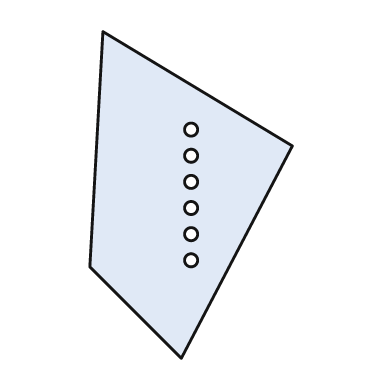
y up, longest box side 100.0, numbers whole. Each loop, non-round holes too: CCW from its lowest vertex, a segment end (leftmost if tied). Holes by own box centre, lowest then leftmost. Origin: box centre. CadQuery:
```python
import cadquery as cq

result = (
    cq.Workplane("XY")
    .moveTo(-3.0, -50.0)
    .lineTo(31.0, 15.0)
    .lineTo(-27.0, 50.0)
    .lineTo(-31.0, -22.0)
    .close()
    .moveTo(0.0, -20.0)
    .circle(2.0)
    .moveTo(0.0, -12.0)
    .circle(2.0)
    .moveTo(0.0, -4.0)
    .circle(2.0)
    .moveTo(0.0, 4.0)
    .circle(2.0)
    .moveTo(0.0, 12.0)
    .circle(2.0)
    .moveTo(0.0, 20.0)
    .circle(2.0)
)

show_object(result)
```